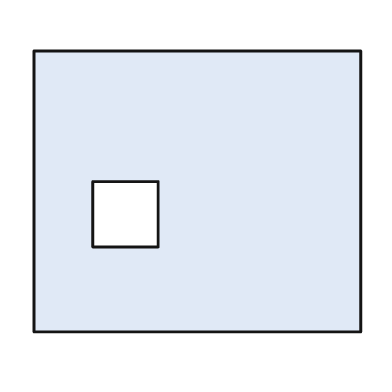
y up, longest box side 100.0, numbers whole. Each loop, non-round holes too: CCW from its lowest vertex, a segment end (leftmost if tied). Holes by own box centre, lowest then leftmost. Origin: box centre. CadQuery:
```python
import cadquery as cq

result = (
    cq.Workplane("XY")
    .moveTo(-50.0, -43.0)
    .lineTo(50.0, -43.0)
    .lineTo(50.0, 43.0)
    .lineTo(-50.0, 43.0)
    .close()
    .moveTo(-32.0, -17.0)
    .lineTo(-12.0, -17.0)
    .lineTo(-12.0, 3.0)
    .lineTo(-32.0, 3.0)
    .close()
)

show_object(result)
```